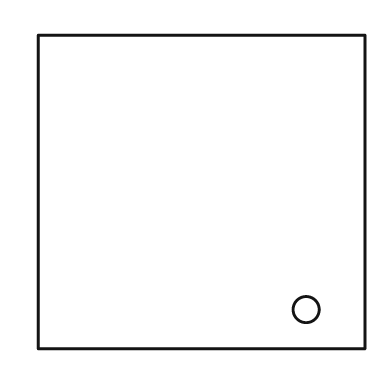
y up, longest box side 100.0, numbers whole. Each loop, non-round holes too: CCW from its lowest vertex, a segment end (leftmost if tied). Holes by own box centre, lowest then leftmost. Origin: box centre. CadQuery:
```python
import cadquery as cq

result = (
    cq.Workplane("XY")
    .moveTo(-50.0, -48.0)
    .lineTo(50.0, -48.0)
    .lineTo(50.0, 48.0)
    .lineTo(-50.0, 48.0)
    .close()
    .moveTo(32.0, -36.0)
    .circle(4.0)
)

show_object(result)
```